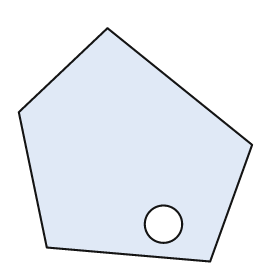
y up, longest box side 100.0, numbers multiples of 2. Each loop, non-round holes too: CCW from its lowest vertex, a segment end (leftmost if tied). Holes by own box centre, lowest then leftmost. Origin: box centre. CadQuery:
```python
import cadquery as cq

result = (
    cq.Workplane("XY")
    .moveTo(32.0, -50.0)
    .lineTo(50.0, 0.0)
    .lineTo(-12.0, 50.0)
    .lineTo(-50.0, 14.0)
    .lineTo(-38.0, -44.0)
    .close()
    .moveTo(12.0, -34.0)
    .circle(8.0)
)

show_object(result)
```